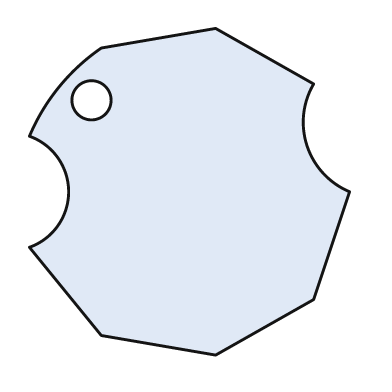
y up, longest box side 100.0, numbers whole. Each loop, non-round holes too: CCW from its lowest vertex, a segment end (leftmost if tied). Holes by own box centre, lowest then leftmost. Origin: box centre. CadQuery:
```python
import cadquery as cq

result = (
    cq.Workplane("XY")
    .moveTo(8.0, -50.0)
    .lineTo(38.0, -33.0)
    .lineTo(49.0, 0.0)
    .threePointArc((36.0, 14.0), (38.0, 33.0))
    .lineTo(8.0, 50.0)
    .lineTo(-27.0, 44.0)
    .threePointArc((-40.0, 32.0), (-49.0, 17.0))
    .threePointArc((-37.0, 0.0), (-49.0, -17.0))
    .lineTo(-27.0, -44.0)
    .close()
    .moveTo(-30.0, 28.0)
    .circle(6.0)
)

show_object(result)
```